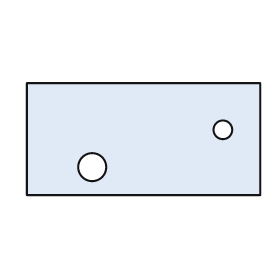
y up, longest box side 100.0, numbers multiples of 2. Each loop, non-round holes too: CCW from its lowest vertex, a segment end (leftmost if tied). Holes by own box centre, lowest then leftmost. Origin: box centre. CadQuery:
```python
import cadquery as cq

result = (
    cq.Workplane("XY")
    .moveTo(-50.0, -24.0)
    .lineTo(50.0, -24.0)
    .lineTo(50.0, 24.0)
    .lineTo(-50.0, 24.0)
    .close()
    .moveTo(-22.0, -12.0)
    .circle(6.0)
    .moveTo(34.0, 4.0)
    .circle(4.0)
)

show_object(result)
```